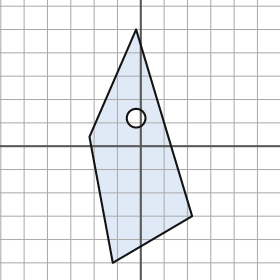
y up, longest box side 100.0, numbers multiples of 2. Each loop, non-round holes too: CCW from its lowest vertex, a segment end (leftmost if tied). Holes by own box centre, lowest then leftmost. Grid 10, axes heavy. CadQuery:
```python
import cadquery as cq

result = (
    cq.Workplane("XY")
    .moveTo(-12.0, -50.0)
    .lineTo(22.0, -30.0)
    .lineTo(-2.0, 50.0)
    .lineTo(-22.0, 4.0)
    .close()
    .moveTo(-2.0, 12.0)
    .circle(4.0)
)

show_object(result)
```